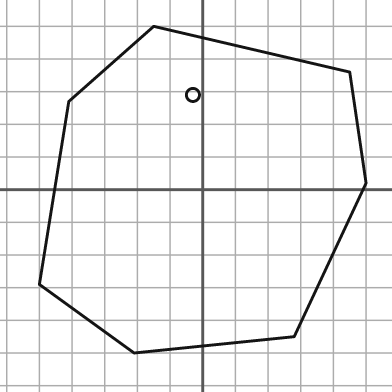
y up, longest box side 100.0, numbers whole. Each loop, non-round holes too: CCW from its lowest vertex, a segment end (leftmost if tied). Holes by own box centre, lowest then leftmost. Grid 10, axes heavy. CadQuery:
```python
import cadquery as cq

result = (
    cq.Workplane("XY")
    .moveTo(-21.0, -50.0)
    .lineTo(28.0, -45.0)
    .lineTo(50.0, 2.0)
    .lineTo(45.0, 36.0)
    .lineTo(-15.0, 50.0)
    .lineTo(-41.0, 27.0)
    .lineTo(-50.0, -29.0)
    .close()
    .moveTo(-3.0, 29.0)
    .circle(2.0)
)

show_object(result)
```